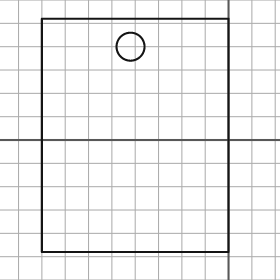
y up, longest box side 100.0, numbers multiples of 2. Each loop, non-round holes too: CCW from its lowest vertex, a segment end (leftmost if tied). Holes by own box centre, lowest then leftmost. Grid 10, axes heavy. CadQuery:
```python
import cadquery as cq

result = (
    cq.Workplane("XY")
    .moveTo(-80.0, -48.0)
    .lineTo(0.0, -48.0)
    .lineTo(0.0, 52.0)
    .lineTo(-80.0, 52.0)
    .close()
    .moveTo(-42.0, 40.0)
    .circle(6.0)
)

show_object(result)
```